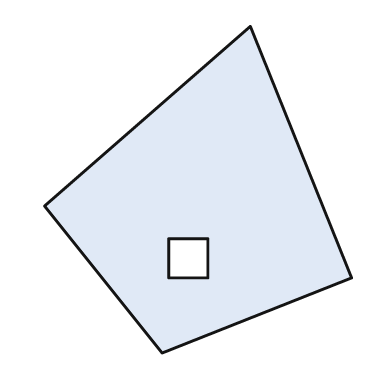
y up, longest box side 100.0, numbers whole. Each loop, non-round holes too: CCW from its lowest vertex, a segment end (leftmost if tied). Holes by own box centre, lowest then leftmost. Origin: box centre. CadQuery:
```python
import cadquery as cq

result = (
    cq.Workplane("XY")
    .moveTo(-11.0, -50.0)
    .lineTo(47.0, -27.0)
    .lineTo(16.0, 50.0)
    .lineTo(-47.0, -5.0)
    .close()
    .moveTo(-9.0, -27.0)
    .lineTo(3.0, -27.0)
    .lineTo(3.0, -15.0)
    .lineTo(-9.0, -15.0)
    .close()
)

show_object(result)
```